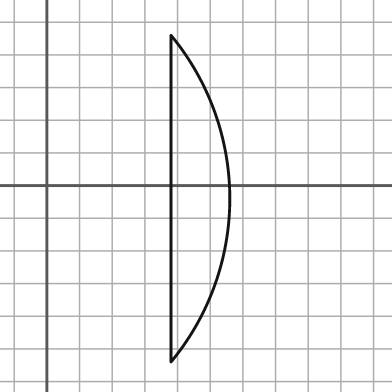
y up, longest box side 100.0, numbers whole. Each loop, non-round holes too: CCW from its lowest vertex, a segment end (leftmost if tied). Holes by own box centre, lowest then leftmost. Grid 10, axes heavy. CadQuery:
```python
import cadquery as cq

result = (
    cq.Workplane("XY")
    .moveTo(38.0, -54.0)
    .threePointArc((56.0, -4.0), (38.0, 46.0))
    .close()
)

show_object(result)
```